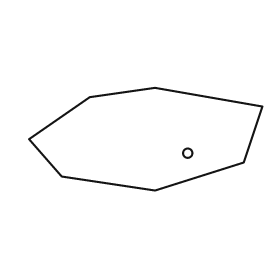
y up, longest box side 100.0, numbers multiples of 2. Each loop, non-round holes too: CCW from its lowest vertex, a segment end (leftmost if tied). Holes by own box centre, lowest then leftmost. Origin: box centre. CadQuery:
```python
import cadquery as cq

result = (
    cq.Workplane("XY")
    .moveTo(4.0, -22.0)
    .lineTo(42.0, -10.0)
    .lineTo(50.0, 14.0)
    .lineTo(4.0, 22.0)
    .lineTo(-24.0, 18.0)
    .lineTo(-50.0, 0.0)
    .lineTo(-36.0, -16.0)
    .close()
    .moveTo(18.0, -6.0)
    .circle(2.0)
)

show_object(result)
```